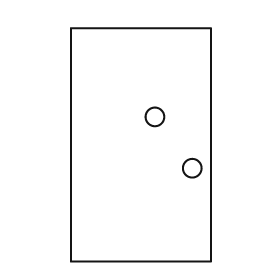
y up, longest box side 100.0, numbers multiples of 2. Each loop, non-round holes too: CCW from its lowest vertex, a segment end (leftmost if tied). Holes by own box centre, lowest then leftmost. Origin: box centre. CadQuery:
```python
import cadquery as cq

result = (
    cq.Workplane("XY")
    .moveTo(-30.0, -50.0)
    .lineTo(30.0, -50.0)
    .lineTo(30.0, 50.0)
    .lineTo(-30.0, 50.0)
    .close()
    .moveTo(22.0, -10.0)
    .circle(4.0)
    .moveTo(6.0, 12.0)
    .circle(4.0)
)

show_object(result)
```